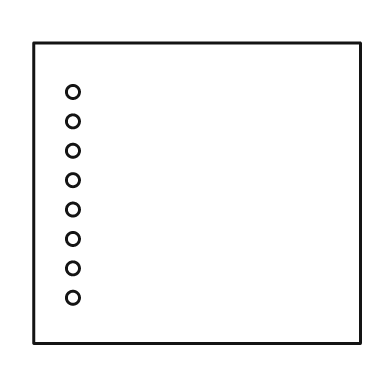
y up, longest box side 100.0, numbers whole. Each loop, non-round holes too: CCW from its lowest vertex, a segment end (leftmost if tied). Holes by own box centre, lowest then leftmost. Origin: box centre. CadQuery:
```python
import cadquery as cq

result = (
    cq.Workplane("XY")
    .moveTo(-50.0, -46.0)
    .lineTo(50.0, -46.0)
    .lineTo(50.0, 46.0)
    .lineTo(-50.0, 46.0)
    .close()
    .moveTo(-38.0, -32.0)
    .circle(2.0)
    .moveTo(-38.0, -23.0)
    .circle(2.0)
    .moveTo(-38.0, -14.0)
    .circle(2.0)
    .moveTo(-38.0, -5.0)
    .circle(2.0)
    .moveTo(-38.0, 4.0)
    .circle(2.0)
    .moveTo(-38.0, 13.0)
    .circle(2.0)
    .moveTo(-38.0, 22.0)
    .circle(2.0)
    .moveTo(-38.0, 31.0)
    .circle(2.0)
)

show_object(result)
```